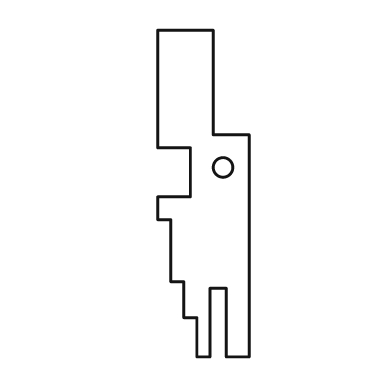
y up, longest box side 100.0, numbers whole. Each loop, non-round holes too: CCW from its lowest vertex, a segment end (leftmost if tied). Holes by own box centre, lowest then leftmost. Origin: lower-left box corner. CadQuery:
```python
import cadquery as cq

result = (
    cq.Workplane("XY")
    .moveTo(12.0, 0.0)
    .lineTo(16.0, 0.0)
    .lineTo(16.0, 21.0)
    .lineTo(21.0, 21.0)
    .lineTo(21.0, 0.0)
    .lineTo(28.0, 0.0)
    .lineTo(28.0, 68.0)
    .lineTo(17.0, 68.0)
    .lineTo(17.0, 100.0)
    .lineTo(0.0, 100.0)
    .lineTo(0.0, 64.0)
    .lineTo(10.0, 64.0)
    .lineTo(10.0, 49.0)
    .lineTo(0.0, 49.0)
    .lineTo(0.0, 42.0)
    .lineTo(4.0, 42.0)
    .lineTo(4.0, 23.0)
    .lineTo(8.0, 23.0)
    .lineTo(8.0, 12.0)
    .lineTo(12.0, 12.0)
    .close()
    .moveTo(20.0, 58.0)
    .circle(3.0)
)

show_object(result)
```